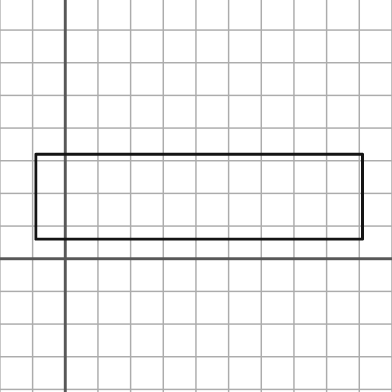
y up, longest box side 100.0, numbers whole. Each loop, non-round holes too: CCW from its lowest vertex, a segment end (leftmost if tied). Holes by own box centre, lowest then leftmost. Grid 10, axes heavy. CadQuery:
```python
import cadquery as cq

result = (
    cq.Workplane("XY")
    .moveTo(-9.0, 6.0)
    .lineTo(91.0, 6.0)
    .lineTo(91.0, 32.0)
    .lineTo(-9.0, 32.0)
    .close()
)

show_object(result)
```